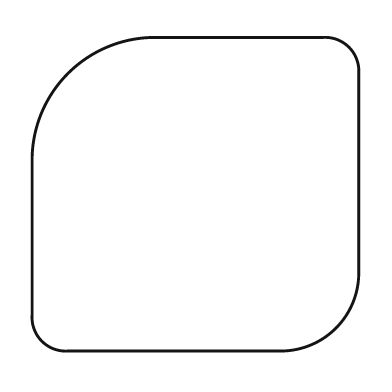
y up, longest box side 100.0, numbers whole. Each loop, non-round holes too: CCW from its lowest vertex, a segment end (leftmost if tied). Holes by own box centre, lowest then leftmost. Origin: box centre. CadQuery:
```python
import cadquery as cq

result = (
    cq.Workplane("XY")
    .moveTo(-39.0, -48.0)
    .lineTo(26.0, -48.0)
    .threePointArc((43.0, -41.0), (50.0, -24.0))
    .lineTo(50.0, 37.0)
    .threePointArc((47.0, 45.0), (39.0, 48.0))
    .lineTo(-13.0, 48.0)
    .threePointArc((-39.0, 37.0), (-50.0, 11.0))
    .lineTo(-50.0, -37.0)
    .threePointArc((-47.0, -45.0), (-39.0, -48.0))
    .close()
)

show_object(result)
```